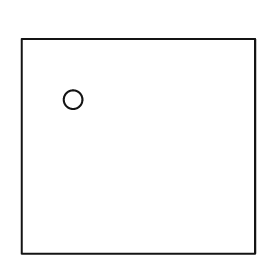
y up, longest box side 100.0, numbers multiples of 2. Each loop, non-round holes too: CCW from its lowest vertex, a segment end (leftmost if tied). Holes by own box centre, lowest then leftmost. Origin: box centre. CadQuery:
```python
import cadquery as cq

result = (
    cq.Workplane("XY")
    .moveTo(-50.0, -46.0)
    .lineTo(50.0, -46.0)
    .lineTo(50.0, 46.0)
    .lineTo(-50.0, 46.0)
    .close()
    .moveTo(-28.0, 20.0)
    .circle(4.0)
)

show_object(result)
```